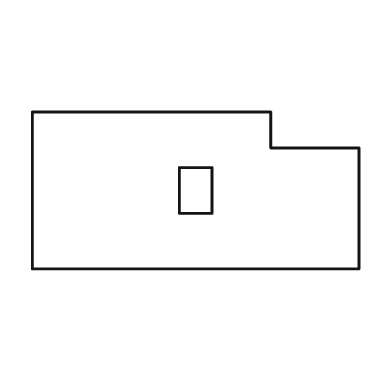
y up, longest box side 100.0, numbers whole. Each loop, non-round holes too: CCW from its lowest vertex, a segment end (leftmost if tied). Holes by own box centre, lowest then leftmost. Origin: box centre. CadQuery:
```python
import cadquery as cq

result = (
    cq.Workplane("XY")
    .moveTo(-50.0, -24.0)
    .lineTo(50.0, -24.0)
    .lineTo(50.0, 13.0)
    .lineTo(23.0, 13.0)
    .lineTo(23.0, 24.0)
    .lineTo(-50.0, 24.0)
    .close()
    .moveTo(-5.0, -7.0)
    .lineTo(5.0, -7.0)
    .lineTo(5.0, 7.0)
    .lineTo(-5.0, 7.0)
    .close()
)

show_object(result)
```